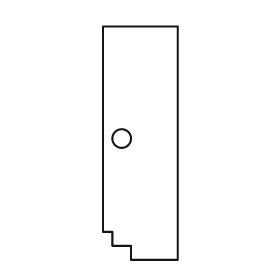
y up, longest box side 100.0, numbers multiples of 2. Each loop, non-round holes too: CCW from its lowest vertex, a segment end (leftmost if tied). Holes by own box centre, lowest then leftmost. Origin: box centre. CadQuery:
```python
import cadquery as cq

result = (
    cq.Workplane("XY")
    .moveTo(-4.0, -50.0)
    .lineTo(16.0, -50.0)
    .lineTo(16.0, 50.0)
    .lineTo(-16.0, 50.0)
    .lineTo(-16.0, -38.0)
    .lineTo(-12.0, -38.0)
    .lineTo(-12.0, -44.0)
    .lineTo(-4.0, -44.0)
    .close()
    .moveTo(-8.0, 2.0)
    .circle(4.0)
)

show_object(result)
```